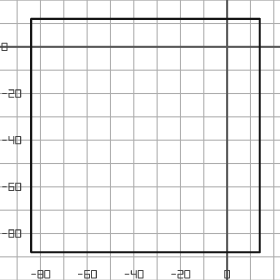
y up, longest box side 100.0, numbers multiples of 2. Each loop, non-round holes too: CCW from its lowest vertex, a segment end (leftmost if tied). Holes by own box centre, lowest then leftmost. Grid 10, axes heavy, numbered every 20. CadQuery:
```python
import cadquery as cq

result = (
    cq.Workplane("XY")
    .moveTo(-84.0, -88.0)
    .lineTo(14.0, -88.0)
    .lineTo(14.0, 12.0)
    .lineTo(-84.0, 12.0)
    .close()
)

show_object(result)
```